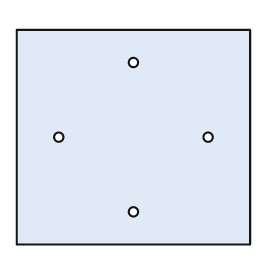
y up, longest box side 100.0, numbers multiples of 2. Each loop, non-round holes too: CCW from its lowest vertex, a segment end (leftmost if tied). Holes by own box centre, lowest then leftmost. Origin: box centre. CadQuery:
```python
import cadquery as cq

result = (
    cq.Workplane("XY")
    .moveTo(-50.0, -46.0)
    .lineTo(50.0, -46.0)
    .lineTo(50.0, 46.0)
    .lineTo(-50.0, 46.0)
    .close()
    .moveTo(0.0, -32.0)
    .circle(2.0)
    .moveTo(-32.0, 0.0)
    .circle(2.0)
    .moveTo(32.0, 0.0)
    .circle(2.0)
    .moveTo(0.0, 32.0)
    .circle(2.0)
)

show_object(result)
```